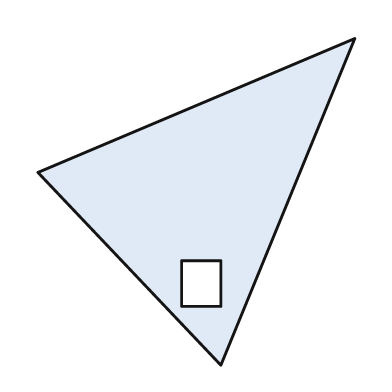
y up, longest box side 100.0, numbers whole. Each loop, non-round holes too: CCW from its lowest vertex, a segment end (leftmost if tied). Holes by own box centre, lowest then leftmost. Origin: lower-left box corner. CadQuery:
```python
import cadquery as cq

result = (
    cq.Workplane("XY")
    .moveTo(56.0, 0.0)
    .lineTo(97.0, 100.0)
    .lineTo(0.0, 59.0)
    .close()
    .moveTo(44.0, 18.0)
    .lineTo(56.0, 18.0)
    .lineTo(56.0, 32.0)
    .lineTo(44.0, 32.0)
    .close()
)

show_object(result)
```